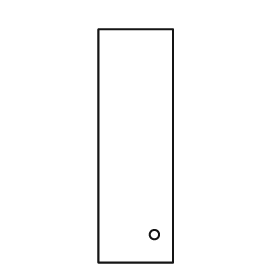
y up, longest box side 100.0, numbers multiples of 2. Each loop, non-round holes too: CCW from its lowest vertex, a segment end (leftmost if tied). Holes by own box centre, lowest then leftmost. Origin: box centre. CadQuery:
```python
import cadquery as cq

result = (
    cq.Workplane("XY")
    .moveTo(-16.0, -50.0)
    .lineTo(16.0, -50.0)
    .lineTo(16.0, 50.0)
    .lineTo(-16.0, 50.0)
    .close()
    .moveTo(8.0, -38.0)
    .circle(2.0)
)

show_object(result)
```